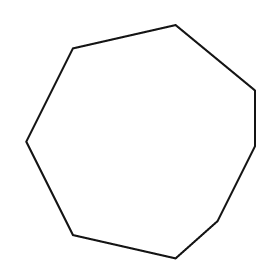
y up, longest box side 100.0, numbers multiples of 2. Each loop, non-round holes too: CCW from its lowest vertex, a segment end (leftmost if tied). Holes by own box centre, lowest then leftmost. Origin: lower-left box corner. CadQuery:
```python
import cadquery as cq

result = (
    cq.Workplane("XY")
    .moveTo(64.0, 0.0)
    .lineTo(82.0, 16.0)
    .lineTo(98.0, 48.0)
    .lineTo(98.0, 72.0)
    .lineTo(64.0, 100.0)
    .lineTo(20.0, 90.0)
    .lineTo(0.0, 50.0)
    .lineTo(20.0, 10.0)
    .close()
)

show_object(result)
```